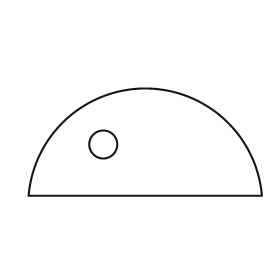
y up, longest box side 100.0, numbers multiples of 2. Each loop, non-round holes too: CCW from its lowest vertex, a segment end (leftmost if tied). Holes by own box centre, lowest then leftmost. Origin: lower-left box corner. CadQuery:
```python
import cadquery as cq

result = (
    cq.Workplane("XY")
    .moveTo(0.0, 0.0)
    .lineTo(100.0, 0.0)
    .threePointArc((50.0, 46.0), (0.0, 0.0))
    .close()
    .moveTo(32.0, 22.0)
    .circle(6.0)
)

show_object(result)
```